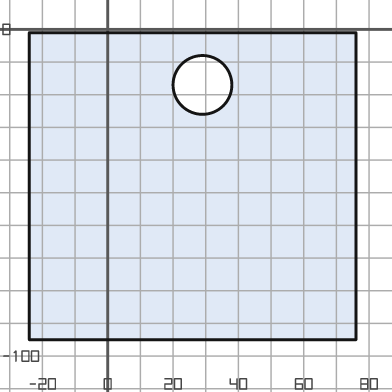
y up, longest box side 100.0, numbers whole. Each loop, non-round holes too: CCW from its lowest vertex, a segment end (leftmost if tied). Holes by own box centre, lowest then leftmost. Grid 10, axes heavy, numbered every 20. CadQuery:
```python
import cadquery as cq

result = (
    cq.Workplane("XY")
    .moveTo(-24.0, -95.0)
    .lineTo(76.0, -95.0)
    .lineTo(76.0, -1.0)
    .lineTo(-24.0, -1.0)
    .close()
    .moveTo(29.0, -17.0)
    .circle(9.0)
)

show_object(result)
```